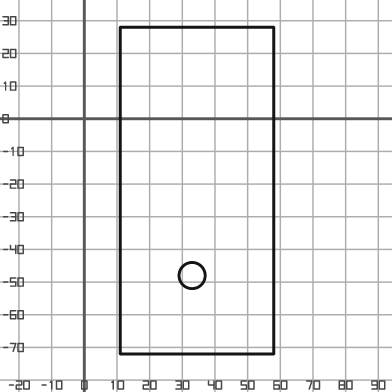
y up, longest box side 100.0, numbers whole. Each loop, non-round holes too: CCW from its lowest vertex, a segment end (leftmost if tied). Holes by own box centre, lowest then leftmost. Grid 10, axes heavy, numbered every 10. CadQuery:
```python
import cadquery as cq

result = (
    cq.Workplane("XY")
    .moveTo(11.0, -72.0)
    .lineTo(58.0, -72.0)
    .lineTo(58.0, 28.0)
    .lineTo(11.0, 28.0)
    .close()
    .moveTo(33.0, -48.0)
    .circle(4.0)
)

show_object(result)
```